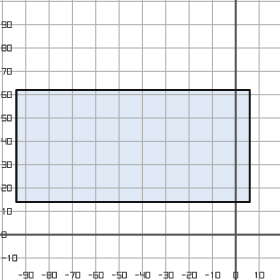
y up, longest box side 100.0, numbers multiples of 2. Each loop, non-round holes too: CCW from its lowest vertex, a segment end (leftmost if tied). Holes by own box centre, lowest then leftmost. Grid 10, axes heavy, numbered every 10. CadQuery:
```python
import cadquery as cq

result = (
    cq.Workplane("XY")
    .moveTo(-94.0, 14.0)
    .lineTo(6.0, 14.0)
    .lineTo(6.0, 62.0)
    .lineTo(-94.0, 62.0)
    .close()
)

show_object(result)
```